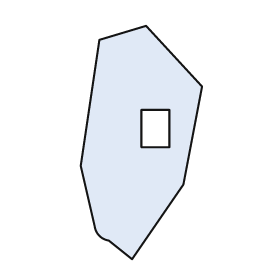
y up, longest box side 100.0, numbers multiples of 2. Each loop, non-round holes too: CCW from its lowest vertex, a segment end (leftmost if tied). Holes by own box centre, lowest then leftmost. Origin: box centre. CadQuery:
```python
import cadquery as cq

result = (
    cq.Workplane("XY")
    .moveTo(-4.0, -50.0)
    .lineTo(18.0, -18.0)
    .lineTo(26.0, 24.0)
    .lineTo(2.0, 50.0)
    .lineTo(-18.0, 44.0)
    .lineTo(-26.0, -10.0)
    .lineTo(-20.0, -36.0)
    .threePointArc((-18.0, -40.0), (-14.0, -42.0))
    .close()
    .moveTo(0.0, -2.0)
    .lineTo(12.0, -2.0)
    .lineTo(12.0, 14.0)
    .lineTo(0.0, 14.0)
    .close()
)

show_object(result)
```